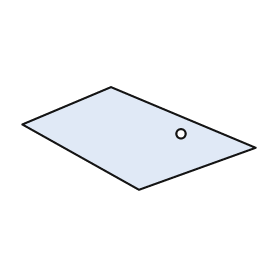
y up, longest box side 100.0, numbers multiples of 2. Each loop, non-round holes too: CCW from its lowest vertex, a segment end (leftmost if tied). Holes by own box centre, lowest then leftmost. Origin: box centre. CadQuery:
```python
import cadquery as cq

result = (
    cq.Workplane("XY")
    .moveTo(0.0, -22.0)
    .lineTo(50.0, -4.0)
    .lineTo(-12.0, 22.0)
    .lineTo(-50.0, 6.0)
    .close()
    .moveTo(18.0, 2.0)
    .circle(2.0)
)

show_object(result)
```